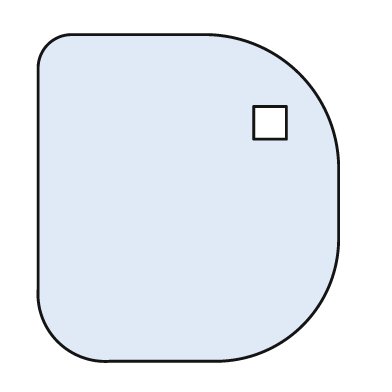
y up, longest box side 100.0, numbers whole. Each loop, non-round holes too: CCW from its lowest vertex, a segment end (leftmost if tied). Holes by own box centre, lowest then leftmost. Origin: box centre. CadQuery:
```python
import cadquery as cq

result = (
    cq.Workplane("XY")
    .moveTo(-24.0, -50.0)
    .lineTo(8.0, -50.0)
    .threePointArc((35.0, -39.0), (46.0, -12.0))
    .lineTo(46.0, 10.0)
    .threePointArc((34.0, 38.0), (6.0, 50.0))
    .lineTo(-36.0, 50.0)
    .threePointArc((-43.0, 47.0), (-46.0, 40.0))
    .lineTo(-46.0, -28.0)
    .threePointArc((-40.0, -44.0), (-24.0, -50.0))
    .close()
    .moveTo(20.0, 18.0)
    .lineTo(30.0, 18.0)
    .lineTo(30.0, 28.0)
    .lineTo(20.0, 28.0)
    .close()
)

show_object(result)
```